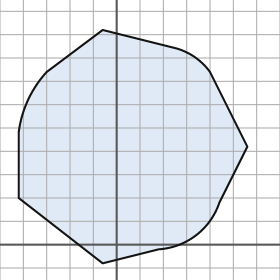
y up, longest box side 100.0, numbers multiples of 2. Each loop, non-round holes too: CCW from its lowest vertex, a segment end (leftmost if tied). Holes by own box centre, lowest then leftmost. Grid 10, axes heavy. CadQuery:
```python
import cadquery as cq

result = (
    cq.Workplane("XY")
    .moveTo(-6.0, -8.0)
    .lineTo(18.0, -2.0)
    .threePointArc((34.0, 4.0), (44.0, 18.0))
    .lineTo(56.0, 42.0)
    .lineTo(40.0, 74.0)
    .threePointArc((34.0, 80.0), (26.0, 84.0))
    .lineTo(-6.0, 92.0)
    .lineTo(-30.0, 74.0)
    .threePointArc((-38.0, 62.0), (-42.0, 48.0))
    .lineTo(-42.0, 20.0)
    .close()
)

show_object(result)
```